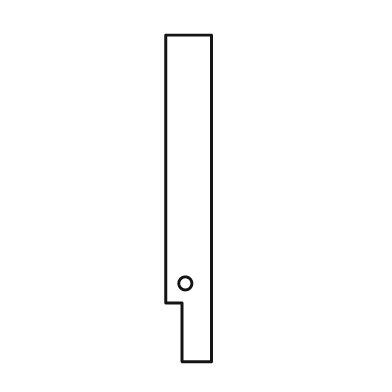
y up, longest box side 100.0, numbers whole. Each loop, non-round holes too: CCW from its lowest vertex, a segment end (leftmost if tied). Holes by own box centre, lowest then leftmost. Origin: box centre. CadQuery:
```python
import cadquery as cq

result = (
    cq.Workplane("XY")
    .moveTo(-2.0, -50.0)
    .lineTo(7.0, -50.0)
    .lineTo(7.0, 50.0)
    .lineTo(-7.0, 50.0)
    .lineTo(-7.0, -32.0)
    .lineTo(-2.0, -32.0)
    .close()
    .moveTo(-1.0, -26.0)
    .circle(2.0)
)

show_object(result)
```